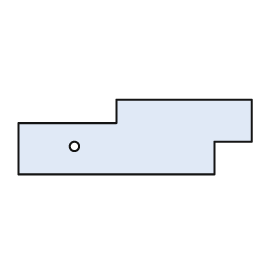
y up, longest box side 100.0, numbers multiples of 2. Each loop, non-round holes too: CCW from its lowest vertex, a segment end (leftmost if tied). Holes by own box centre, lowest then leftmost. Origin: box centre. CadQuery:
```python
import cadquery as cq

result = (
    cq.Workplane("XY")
    .moveTo(-50.0, -16.0)
    .lineTo(34.0, -16.0)
    .lineTo(34.0, -2.0)
    .lineTo(50.0, -2.0)
    .lineTo(50.0, 16.0)
    .lineTo(-8.0, 16.0)
    .lineTo(-8.0, 6.0)
    .lineTo(-50.0, 6.0)
    .close()
    .moveTo(-26.0, -4.0)
    .circle(2.0)
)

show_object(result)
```